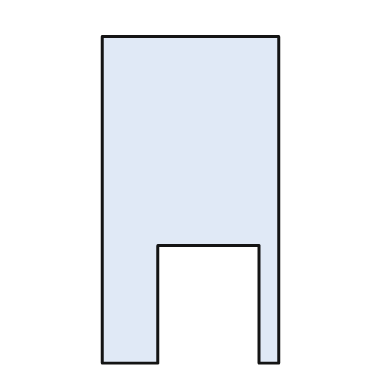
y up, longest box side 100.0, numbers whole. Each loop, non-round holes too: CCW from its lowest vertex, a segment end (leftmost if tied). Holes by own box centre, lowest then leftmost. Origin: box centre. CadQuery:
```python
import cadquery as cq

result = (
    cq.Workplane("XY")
    .moveTo(-27.0, -50.0)
    .lineTo(-10.0, -50.0)
    .lineTo(-10.0, -14.0)
    .lineTo(21.0, -14.0)
    .lineTo(21.0, -50.0)
    .lineTo(27.0, -50.0)
    .lineTo(27.0, 50.0)
    .lineTo(-27.0, 50.0)
    .close()
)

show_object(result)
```